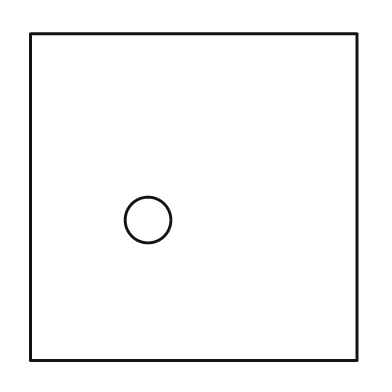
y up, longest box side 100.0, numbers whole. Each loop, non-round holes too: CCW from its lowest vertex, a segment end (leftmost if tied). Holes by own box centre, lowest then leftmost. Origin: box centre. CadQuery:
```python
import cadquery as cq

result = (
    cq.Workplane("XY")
    .moveTo(-50.0, -50.0)
    .lineTo(50.0, -50.0)
    .lineTo(50.0, 50.0)
    .lineTo(-50.0, 50.0)
    .close()
    .moveTo(-14.0, -7.0)
    .circle(7.0)
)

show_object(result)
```